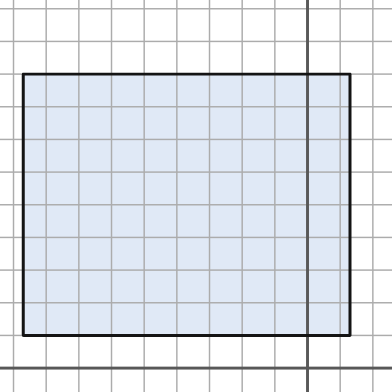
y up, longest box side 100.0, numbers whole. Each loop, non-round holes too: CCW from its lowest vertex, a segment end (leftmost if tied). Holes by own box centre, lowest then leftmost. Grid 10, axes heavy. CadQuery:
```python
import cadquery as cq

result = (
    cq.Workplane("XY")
    .moveTo(-87.0, 10.0)
    .lineTo(13.0, 10.0)
    .lineTo(13.0, 90.0)
    .lineTo(-87.0, 90.0)
    .close()
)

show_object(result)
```